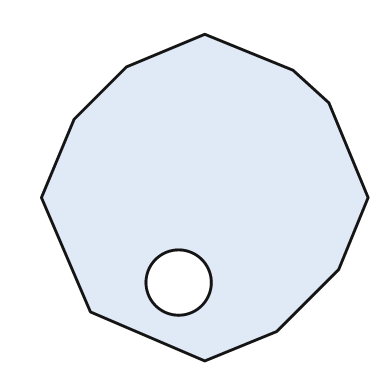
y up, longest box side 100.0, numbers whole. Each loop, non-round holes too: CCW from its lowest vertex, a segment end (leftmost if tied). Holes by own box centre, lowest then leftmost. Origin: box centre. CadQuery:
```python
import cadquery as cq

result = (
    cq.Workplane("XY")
    .moveTo(0.0, -50.0)
    .lineTo(22.0, -41.0)
    .lineTo(41.0, -22.0)
    .lineTo(50.0, 0.0)
    .lineTo(38.0, 29.0)
    .lineTo(27.0, 39.0)
    .lineTo(0.0, 50.0)
    .lineTo(-24.0, 40.0)
    .lineTo(-40.0, 24.0)
    .lineTo(-50.0, 0.0)
    .lineTo(-35.0, -35.0)
    .close()
    .moveTo(-8.0, -26.0)
    .circle(10.0)
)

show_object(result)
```